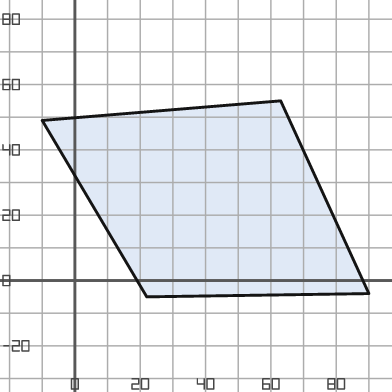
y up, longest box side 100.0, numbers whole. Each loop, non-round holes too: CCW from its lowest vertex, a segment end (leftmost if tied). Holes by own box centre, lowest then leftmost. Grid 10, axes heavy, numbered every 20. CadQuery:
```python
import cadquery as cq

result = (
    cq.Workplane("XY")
    .moveTo(22.0, -5.0)
    .lineTo(90.0, -4.0)
    .lineTo(63.0, 55.0)
    .lineTo(-10.0, 49.0)
    .close()
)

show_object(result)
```